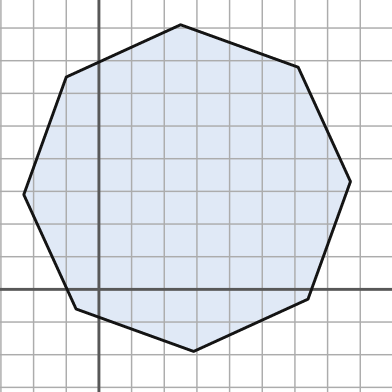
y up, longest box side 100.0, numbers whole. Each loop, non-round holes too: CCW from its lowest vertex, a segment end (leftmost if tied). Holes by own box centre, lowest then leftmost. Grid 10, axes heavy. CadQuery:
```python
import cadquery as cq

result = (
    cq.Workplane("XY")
    .moveTo(29.0, -19.0)
    .lineTo(64.0, -3.0)
    .lineTo(77.0, 33.0)
    .lineTo(61.0, 68.0)
    .lineTo(25.0, 81.0)
    .lineTo(-10.0, 65.0)
    .lineTo(-23.0, 29.0)
    .lineTo(-7.0, -6.0)
    .close()
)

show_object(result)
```